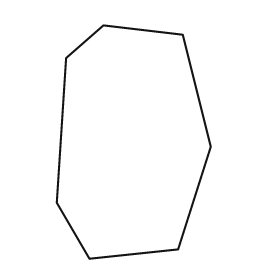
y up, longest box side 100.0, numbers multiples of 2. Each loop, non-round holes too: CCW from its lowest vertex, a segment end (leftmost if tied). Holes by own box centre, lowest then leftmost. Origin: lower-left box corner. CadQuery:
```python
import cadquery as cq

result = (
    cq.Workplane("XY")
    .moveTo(14.0, 0.0)
    .lineTo(52.0, 4.0)
    .lineTo(66.0, 48.0)
    .lineTo(54.0, 96.0)
    .lineTo(20.0, 100.0)
    .lineTo(4.0, 86.0)
    .lineTo(0.0, 24.0)
    .close()
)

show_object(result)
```